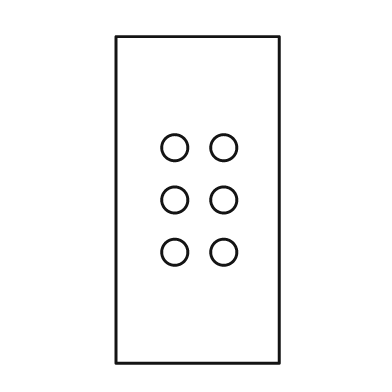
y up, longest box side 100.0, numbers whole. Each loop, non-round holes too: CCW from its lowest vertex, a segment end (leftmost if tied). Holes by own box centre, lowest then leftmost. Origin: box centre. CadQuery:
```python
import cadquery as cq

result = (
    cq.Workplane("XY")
    .moveTo(-25.0, -50.0)
    .lineTo(25.0, -50.0)
    .lineTo(25.0, 50.0)
    .lineTo(-25.0, 50.0)
    .close()
    .moveTo(-7.0, -16.0)
    .circle(4.0)
    .moveTo(8.0, -16.0)
    .circle(4.0)
    .moveTo(-7.0, 0.0)
    .circle(4.0)
    .moveTo(8.0, 0.0)
    .circle(4.0)
    .moveTo(-7.0, 16.0)
    .circle(4.0)
    .moveTo(8.0, 16.0)
    .circle(4.0)
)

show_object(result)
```